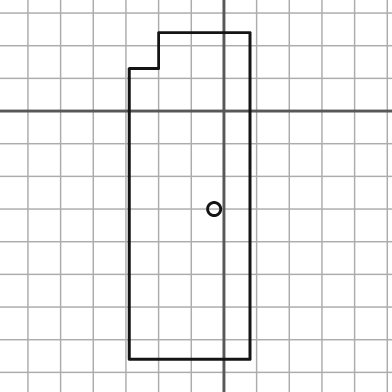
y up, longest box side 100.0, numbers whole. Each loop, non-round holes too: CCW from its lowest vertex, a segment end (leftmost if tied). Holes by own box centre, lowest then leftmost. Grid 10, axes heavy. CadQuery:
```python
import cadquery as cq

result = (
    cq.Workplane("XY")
    .moveTo(-29.0, -76.0)
    .lineTo(8.0, -76.0)
    .lineTo(8.0, 24.0)
    .lineTo(-20.0, 24.0)
    .lineTo(-20.0, 13.0)
    .lineTo(-29.0, 13.0)
    .close()
    .moveTo(-3.0, -30.0)
    .circle(2.0)
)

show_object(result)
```